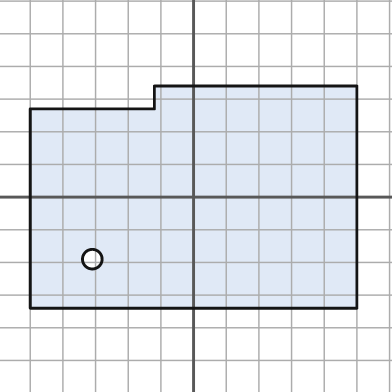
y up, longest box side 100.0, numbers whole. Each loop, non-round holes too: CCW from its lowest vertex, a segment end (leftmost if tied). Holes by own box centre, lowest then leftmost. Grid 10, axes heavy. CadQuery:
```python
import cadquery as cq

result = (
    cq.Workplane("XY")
    .moveTo(-50.0, -34.0)
    .lineTo(50.0, -34.0)
    .lineTo(50.0, 34.0)
    .lineTo(-12.0, 34.0)
    .lineTo(-12.0, 27.0)
    .lineTo(-50.0, 27.0)
    .close()
    .moveTo(-31.0, -19.0)
    .circle(3.0)
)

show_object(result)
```